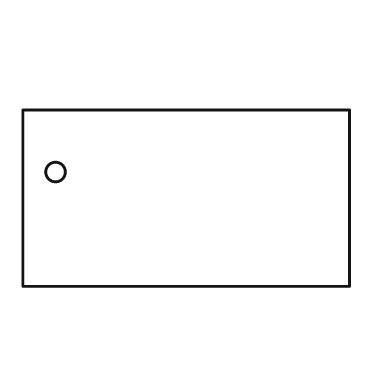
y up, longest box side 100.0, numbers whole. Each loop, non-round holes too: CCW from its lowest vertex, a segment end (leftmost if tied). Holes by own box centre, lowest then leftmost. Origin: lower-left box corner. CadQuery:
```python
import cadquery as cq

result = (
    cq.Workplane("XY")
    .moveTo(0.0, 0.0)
    .lineTo(100.0, 0.0)
    .lineTo(100.0, 54.0)
    .lineTo(0.0, 54.0)
    .close()
    .moveTo(10.0, 35.0)
    .circle(3.0)
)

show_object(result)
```